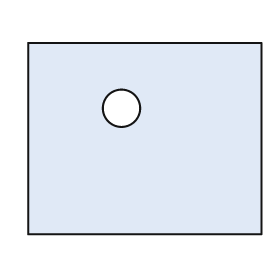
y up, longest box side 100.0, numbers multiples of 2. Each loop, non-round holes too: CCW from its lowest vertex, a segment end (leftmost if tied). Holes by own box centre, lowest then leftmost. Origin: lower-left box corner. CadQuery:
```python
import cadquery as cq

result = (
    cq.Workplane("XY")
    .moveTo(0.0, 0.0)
    .lineTo(100.0, 0.0)
    .lineTo(100.0, 82.0)
    .lineTo(0.0, 82.0)
    .close()
    .moveTo(40.0, 54.0)
    .circle(8.0)
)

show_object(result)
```